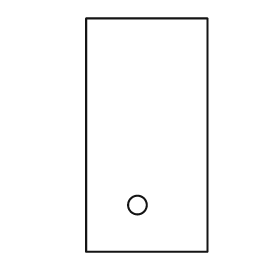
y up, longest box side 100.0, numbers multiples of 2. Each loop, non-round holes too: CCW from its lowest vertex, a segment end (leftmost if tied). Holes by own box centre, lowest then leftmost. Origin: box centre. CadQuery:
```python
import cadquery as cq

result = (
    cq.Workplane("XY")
    .moveTo(-26.0, -50.0)
    .lineTo(26.0, -50.0)
    .lineTo(26.0, 50.0)
    .lineTo(-26.0, 50.0)
    .close()
    .moveTo(-4.0, -30.0)
    .circle(4.0)
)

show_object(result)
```